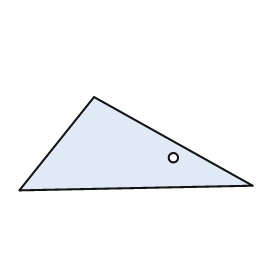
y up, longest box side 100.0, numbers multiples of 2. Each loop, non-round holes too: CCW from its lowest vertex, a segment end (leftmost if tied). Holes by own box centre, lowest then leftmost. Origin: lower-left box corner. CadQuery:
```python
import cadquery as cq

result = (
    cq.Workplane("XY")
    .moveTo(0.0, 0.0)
    .lineTo(100.0, 2.0)
    .lineTo(32.0, 40.0)
    .close()
    .moveTo(66.0, 14.0)
    .circle(2.0)
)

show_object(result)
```